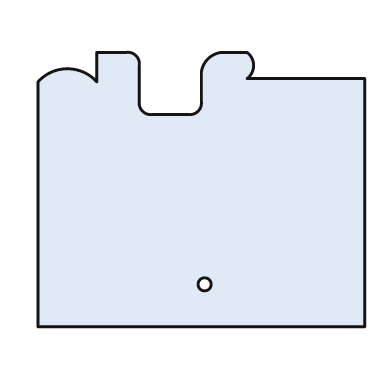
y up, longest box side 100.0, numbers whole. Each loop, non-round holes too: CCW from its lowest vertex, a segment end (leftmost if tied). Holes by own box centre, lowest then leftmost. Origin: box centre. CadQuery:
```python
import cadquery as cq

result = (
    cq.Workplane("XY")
    .moveTo(-50.0, -42.0)
    .lineTo(50.0, -42.0)
    .lineTo(50.0, 34.0)
    .lineTo(14.0, 34.0)
    .threePointArc((16.0, 38.0), (14.0, 42.0))
    .lineTo(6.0, 42.0)
    .threePointArc((2.0, 40.0), (0.0, 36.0))
    .lineTo(0.0, 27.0)
    .threePointArc((-1.0, 24.0), (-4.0, 23.0))
    .lineTo(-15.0, 23.0)
    .threePointArc((-18.0, 24.0), (-19.0, 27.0))
    .lineTo(-19.0, 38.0)
    .threePointArc((-20.0, 41.0), (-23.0, 42.0))
    .lineTo(-32.0, 42.0)
    .lineTo(-32.0, 33.0)
    .threePointArc((-41.0, 37.0), (-50.0, 33.0))
    .close()
    .moveTo(1.0, -29.0)
    .circle(2.0)
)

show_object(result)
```